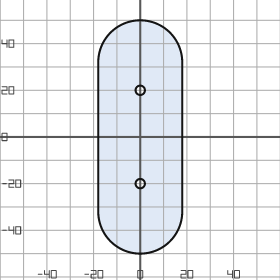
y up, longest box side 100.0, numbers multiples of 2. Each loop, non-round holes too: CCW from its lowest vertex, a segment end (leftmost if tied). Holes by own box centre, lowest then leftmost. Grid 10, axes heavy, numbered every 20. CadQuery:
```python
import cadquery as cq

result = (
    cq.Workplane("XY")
    .moveTo(-18.0, -32.0)
    .threePointArc((0.0, -50.0), (18.0, -32.0))
    .lineTo(18.0, 32.0)
    .threePointArc((0.0, 50.0), (-18.0, 32.0))
    .close()
    .moveTo(0.0, -20.0)
    .circle(2.0)
    .moveTo(0.0, 20.0)
    .circle(2.0)
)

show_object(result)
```